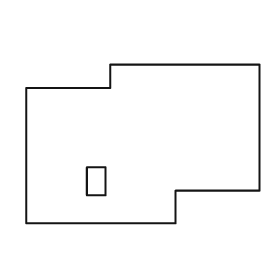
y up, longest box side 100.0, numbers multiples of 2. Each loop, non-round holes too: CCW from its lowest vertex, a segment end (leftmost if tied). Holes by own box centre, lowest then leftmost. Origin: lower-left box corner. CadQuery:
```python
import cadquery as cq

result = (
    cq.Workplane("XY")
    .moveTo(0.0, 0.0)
    .lineTo(64.0, 0.0)
    .lineTo(64.0, 14.0)
    .lineTo(100.0, 14.0)
    .lineTo(100.0, 68.0)
    .lineTo(36.0, 68.0)
    .lineTo(36.0, 58.0)
    .lineTo(0.0, 58.0)
    .close()
    .moveTo(26.0, 12.0)
    .lineTo(34.0, 12.0)
    .lineTo(34.0, 24.0)
    .lineTo(26.0, 24.0)
    .close()
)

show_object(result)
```